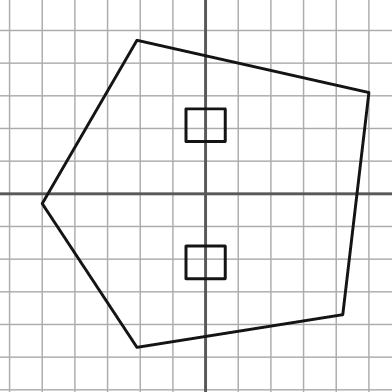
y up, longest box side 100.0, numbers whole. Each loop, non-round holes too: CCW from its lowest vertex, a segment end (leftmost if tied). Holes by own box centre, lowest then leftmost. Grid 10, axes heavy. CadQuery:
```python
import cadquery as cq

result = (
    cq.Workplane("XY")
    .moveTo(-21.0, -47.0)
    .lineTo(42.0, -37.0)
    .lineTo(50.0, 31.0)
    .lineTo(-21.0, 47.0)
    .lineTo(-50.0, -3.0)
    .close()
    .moveTo(-6.0, -26.0)
    .lineTo(6.0, -26.0)
    .lineTo(6.0, -16.0)
    .lineTo(-6.0, -16.0)
    .close()
    .moveTo(-6.0, 16.0)
    .lineTo(6.0, 16.0)
    .lineTo(6.0, 26.0)
    .lineTo(-6.0, 26.0)
    .close()
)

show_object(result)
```